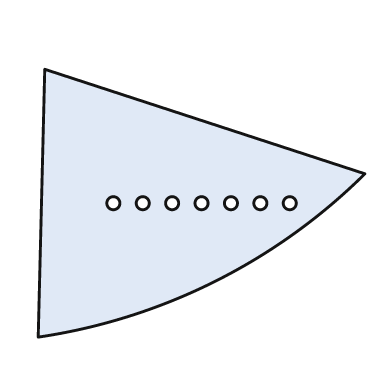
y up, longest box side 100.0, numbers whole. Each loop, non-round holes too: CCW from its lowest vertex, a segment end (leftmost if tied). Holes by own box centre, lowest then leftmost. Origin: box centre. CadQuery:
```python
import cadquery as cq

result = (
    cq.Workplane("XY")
    .moveTo(-50.0, -41.0)
    .threePointArc((4.0, -24.0), (50.0, 9.0))
    .lineTo(-48.0, 41.0)
    .close()
    .moveTo(-27.0, 0.0)
    .circle(2.0)
    .moveTo(-18.0, 0.0)
    .circle(2.0)
    .moveTo(-9.0, 0.0)
    .circle(2.0)
    .moveTo(0.0, 0.0)
    .circle(2.0)
    .moveTo(9.0, 0.0)
    .circle(2.0)
    .moveTo(18.0, 0.0)
    .circle(2.0)
    .moveTo(27.0, 0.0)
    .circle(2.0)
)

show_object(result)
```